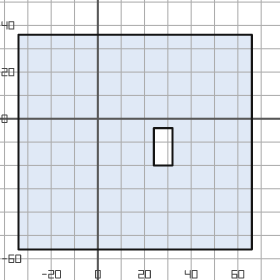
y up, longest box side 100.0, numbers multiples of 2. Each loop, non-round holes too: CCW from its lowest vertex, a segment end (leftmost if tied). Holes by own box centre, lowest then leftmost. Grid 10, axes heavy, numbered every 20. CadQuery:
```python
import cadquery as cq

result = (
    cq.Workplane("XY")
    .moveTo(-34.0, -56.0)
    .lineTo(66.0, -56.0)
    .lineTo(66.0, 36.0)
    .lineTo(-34.0, 36.0)
    .close()
    .moveTo(24.0, -20.0)
    .lineTo(32.0, -20.0)
    .lineTo(32.0, -4.0)
    .lineTo(24.0, -4.0)
    .close()
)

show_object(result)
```